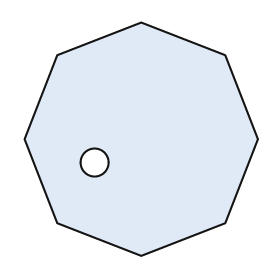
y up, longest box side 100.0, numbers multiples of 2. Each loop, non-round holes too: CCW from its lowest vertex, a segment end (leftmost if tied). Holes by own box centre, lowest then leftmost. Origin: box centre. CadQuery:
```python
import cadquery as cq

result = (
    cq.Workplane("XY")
    .moveTo(0.0, -50.0)
    .lineTo(36.0, -36.0)
    .lineTo(50.0, 0.0)
    .lineTo(36.0, 36.0)
    .lineTo(0.0, 50.0)
    .lineTo(-36.0, 36.0)
    .lineTo(-50.0, 0.0)
    .lineTo(-36.0, -36.0)
    .close()
    .moveTo(-20.0, -10.0)
    .circle(6.0)
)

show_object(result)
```